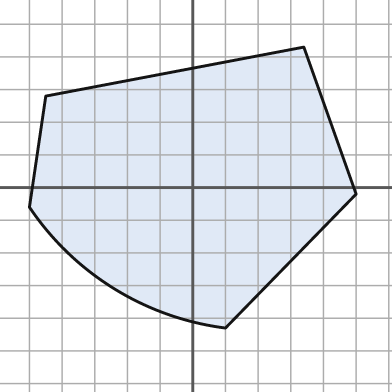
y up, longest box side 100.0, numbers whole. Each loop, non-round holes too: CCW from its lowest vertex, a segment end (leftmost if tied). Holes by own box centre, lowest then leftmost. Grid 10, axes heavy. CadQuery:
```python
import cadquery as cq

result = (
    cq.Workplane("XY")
    .moveTo(10.0, -43.0)
    .lineTo(50.0, -2.0)
    .lineTo(34.0, 43.0)
    .lineTo(-45.0, 28.0)
    .lineTo(-50.0, -6.0)
    .threePointArc((-24.0, -31.0), (10.0, -43.0))
    .close()
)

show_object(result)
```